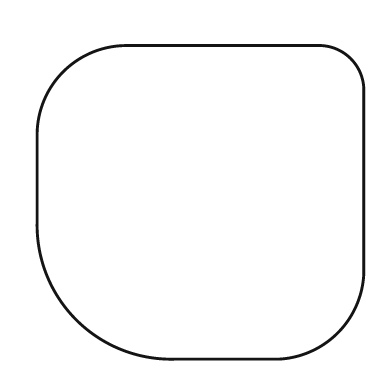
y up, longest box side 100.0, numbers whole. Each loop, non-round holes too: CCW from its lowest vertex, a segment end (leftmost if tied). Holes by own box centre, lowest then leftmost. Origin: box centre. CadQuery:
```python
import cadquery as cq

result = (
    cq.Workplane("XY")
    .moveTo(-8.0, -48.0)
    .lineTo(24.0, -48.0)
    .threePointArc((42.0, -40.0), (50.0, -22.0))
    .lineTo(50.0, 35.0)
    .threePointArc((46.0, 44.0), (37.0, 48.0))
    .lineTo(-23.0, 48.0)
    .threePointArc((-42.0, 40.0), (-50.0, 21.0))
    .lineTo(-50.0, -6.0)
    .threePointArc((-38.0, -36.0), (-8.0, -48.0))
    .close()
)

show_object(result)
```